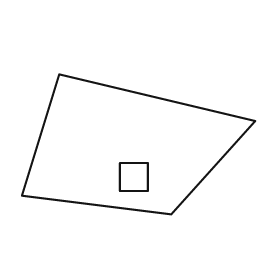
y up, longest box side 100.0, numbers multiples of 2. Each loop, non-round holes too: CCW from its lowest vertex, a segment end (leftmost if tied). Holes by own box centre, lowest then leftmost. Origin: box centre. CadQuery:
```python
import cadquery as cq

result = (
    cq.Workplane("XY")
    .moveTo(14.0, -30.0)
    .lineTo(50.0, 10.0)
    .lineTo(-34.0, 30.0)
    .lineTo(-50.0, -22.0)
    .close()
    .moveTo(-8.0, -20.0)
    .lineTo(4.0, -20.0)
    .lineTo(4.0, -8.0)
    .lineTo(-8.0, -8.0)
    .close()
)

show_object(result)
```